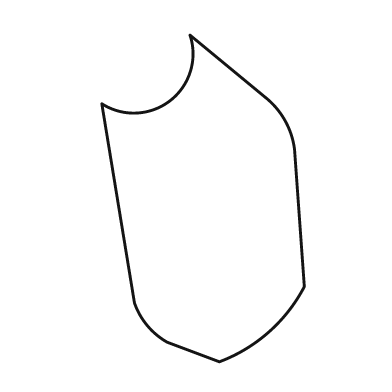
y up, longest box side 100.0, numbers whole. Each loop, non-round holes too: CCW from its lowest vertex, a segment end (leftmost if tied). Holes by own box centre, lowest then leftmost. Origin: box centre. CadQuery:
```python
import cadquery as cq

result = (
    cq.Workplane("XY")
    .moveTo(5.0, -50.0)
    .threePointArc((20.0, -41.0), (31.0, -27.0))
    .lineTo(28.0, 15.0)
    .threePointArc((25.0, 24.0), (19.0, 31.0))
    .lineTo(-4.0, 50.0)
    .threePointArc((-10.0, 30.0), (-31.0, 29.0))
    .lineTo(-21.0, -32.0)
    .threePointArc((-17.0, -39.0), (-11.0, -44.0))
    .close()
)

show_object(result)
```